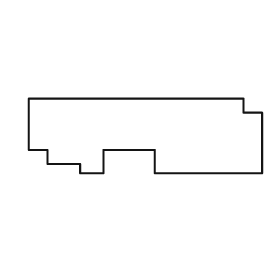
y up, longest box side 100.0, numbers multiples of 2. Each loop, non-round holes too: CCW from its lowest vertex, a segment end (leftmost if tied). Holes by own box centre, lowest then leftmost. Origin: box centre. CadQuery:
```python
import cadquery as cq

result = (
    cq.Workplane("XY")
    .moveTo(-28.0, -16.0)
    .lineTo(-18.0, -16.0)
    .lineTo(-18.0, -6.0)
    .lineTo(4.0, -6.0)
    .lineTo(4.0, -16.0)
    .lineTo(50.0, -16.0)
    .lineTo(50.0, 10.0)
    .lineTo(42.0, 10.0)
    .lineTo(42.0, 16.0)
    .lineTo(-50.0, 16.0)
    .lineTo(-50.0, -6.0)
    .lineTo(-42.0, -6.0)
    .lineTo(-42.0, -12.0)
    .lineTo(-28.0, -12.0)
    .close()
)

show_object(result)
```